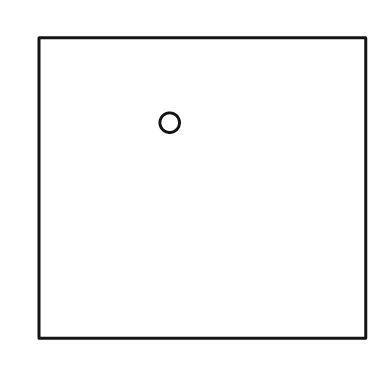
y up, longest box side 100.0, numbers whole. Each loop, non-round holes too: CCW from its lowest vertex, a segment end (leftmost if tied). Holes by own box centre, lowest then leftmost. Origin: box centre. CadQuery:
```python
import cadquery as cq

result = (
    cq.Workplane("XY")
    .moveTo(-50.0, -46.0)
    .lineTo(50.0, -46.0)
    .lineTo(50.0, 46.0)
    .lineTo(-50.0, 46.0)
    .close()
    .moveTo(-10.0, 20.0)
    .circle(3.0)
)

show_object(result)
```